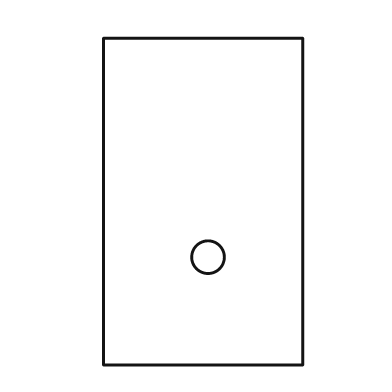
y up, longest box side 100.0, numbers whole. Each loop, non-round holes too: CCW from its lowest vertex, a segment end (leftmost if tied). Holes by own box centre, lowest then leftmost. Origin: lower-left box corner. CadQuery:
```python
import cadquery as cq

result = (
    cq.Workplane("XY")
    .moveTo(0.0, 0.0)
    .lineTo(61.0, 0.0)
    .lineTo(61.0, 100.0)
    .lineTo(0.0, 100.0)
    .close()
    .moveTo(32.0, 33.0)
    .circle(5.0)
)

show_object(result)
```